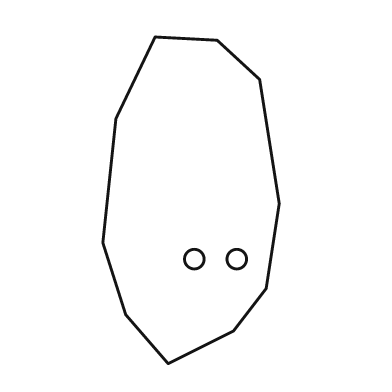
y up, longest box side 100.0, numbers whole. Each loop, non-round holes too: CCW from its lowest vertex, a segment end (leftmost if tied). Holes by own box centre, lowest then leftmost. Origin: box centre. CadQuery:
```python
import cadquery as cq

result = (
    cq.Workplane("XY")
    .moveTo(-7.0, -50.0)
    .lineTo(13.0, -40.0)
    .lineTo(23.0, -27.0)
    .lineTo(27.0, -1.0)
    .lineTo(21.0, 37.0)
    .lineTo(8.0, 49.0)
    .lineTo(-11.0, 50.0)
    .lineTo(-23.0, 25.0)
    .lineTo(-27.0, -13.0)
    .lineTo(-20.0, -35.0)
    .close()
    .moveTo(1.0, -18.0)
    .circle(3.0)
    .moveTo(14.0, -18.0)
    .circle(3.0)
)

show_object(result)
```